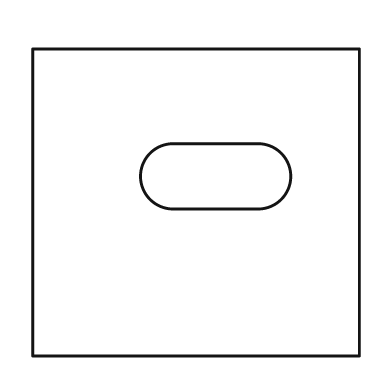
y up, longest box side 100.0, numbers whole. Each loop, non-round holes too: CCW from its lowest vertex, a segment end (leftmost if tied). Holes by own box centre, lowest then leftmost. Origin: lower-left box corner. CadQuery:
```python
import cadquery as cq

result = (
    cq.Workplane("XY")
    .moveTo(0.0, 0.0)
    .lineTo(100.0, 0.0)
    .lineTo(100.0, 94.0)
    .lineTo(0.0, 94.0)
    .close()
    .moveTo(43.0, 45.0)
    .lineTo(69.0, 45.0)
    .threePointArc((79.0, 55.0), (69.0, 65.0))
    .lineTo(43.0, 65.0)
    .threePointArc((33.0, 55.0), (43.0, 45.0))
    .close()
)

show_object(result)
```